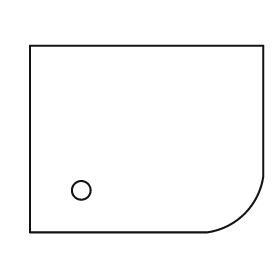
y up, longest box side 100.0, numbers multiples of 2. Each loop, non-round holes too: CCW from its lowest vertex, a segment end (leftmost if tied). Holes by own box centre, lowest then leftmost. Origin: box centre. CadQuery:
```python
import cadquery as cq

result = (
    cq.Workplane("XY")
    .moveTo(-50.0, -40.0)
    .lineTo(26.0, -40.0)
    .threePointArc((42.0, -32.0), (50.0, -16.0))
    .lineTo(50.0, 40.0)
    .lineTo(-50.0, 40.0)
    .close()
    .moveTo(-28.0, -22.0)
    .circle(4.0)
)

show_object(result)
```